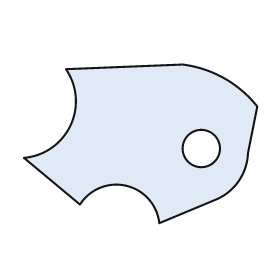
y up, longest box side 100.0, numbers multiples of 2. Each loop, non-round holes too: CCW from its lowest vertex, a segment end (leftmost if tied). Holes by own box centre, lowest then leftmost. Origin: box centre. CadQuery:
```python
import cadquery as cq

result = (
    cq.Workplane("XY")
    .moveTo(8.0, -34.0)
    .lineTo(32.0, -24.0)
    .threePointArc((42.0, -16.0), (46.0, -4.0))
    .lineTo(50.0, 16.0)
    .threePointArc((36.0, 28.0), (18.0, 34.0))
    .lineTo(-32.0, 32.0)
    .threePointArc((-30.0, 8.0), (-50.0, -6.0))
    .lineTo(-26.0, -26.0)
    .threePointArc((-6.0, -18.0), (8.0, -34.0))
    .close()
    .moveTo(26.0, -2.0)
    .circle(8.0)
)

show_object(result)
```